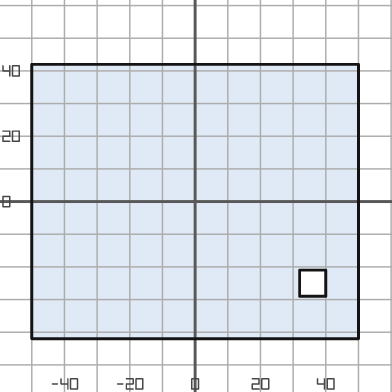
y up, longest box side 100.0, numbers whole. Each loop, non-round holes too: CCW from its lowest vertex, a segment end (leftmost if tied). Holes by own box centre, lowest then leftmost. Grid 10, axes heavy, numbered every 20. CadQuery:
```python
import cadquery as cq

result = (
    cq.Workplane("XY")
    .moveTo(-50.0, -42.0)
    .lineTo(50.0, -42.0)
    .lineTo(50.0, 42.0)
    .lineTo(-50.0, 42.0)
    .close()
    .moveTo(32.0, -29.0)
    .lineTo(40.0, -29.0)
    .lineTo(40.0, -21.0)
    .lineTo(32.0, -21.0)
    .close()
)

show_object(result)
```